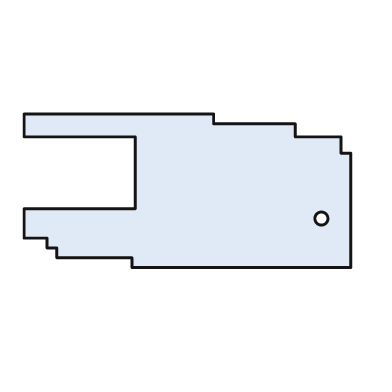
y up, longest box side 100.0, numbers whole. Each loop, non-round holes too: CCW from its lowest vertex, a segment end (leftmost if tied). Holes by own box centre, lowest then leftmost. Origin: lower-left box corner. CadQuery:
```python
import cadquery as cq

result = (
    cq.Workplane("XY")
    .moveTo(33.0, 0.0)
    .lineTo(100.0, 0.0)
    .lineTo(100.0, 35.0)
    .lineTo(97.0, 35.0)
    .lineTo(97.0, 40.0)
    .lineTo(83.0, 40.0)
    .lineTo(83.0, 44.0)
    .lineTo(58.0, 44.0)
    .lineTo(58.0, 47.0)
    .lineTo(0.0, 47.0)
    .lineTo(0.0, 40.0)
    .lineTo(34.0, 40.0)
    .lineTo(34.0, 18.0)
    .lineTo(0.0, 18.0)
    .lineTo(0.0, 9.0)
    .lineTo(7.0, 9.0)
    .lineTo(7.0, 6.0)
    .lineTo(10.0, 6.0)
    .lineTo(10.0, 3.0)
    .lineTo(33.0, 3.0)
    .close()
    .moveTo(91.0, 15.0)
    .circle(2.0)
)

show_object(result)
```